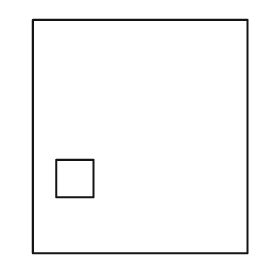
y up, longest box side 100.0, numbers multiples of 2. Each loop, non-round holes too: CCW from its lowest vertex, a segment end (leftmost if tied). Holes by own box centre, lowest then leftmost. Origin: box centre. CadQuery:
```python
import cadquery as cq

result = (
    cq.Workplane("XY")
    .moveTo(-46.0, -50.0)
    .lineTo(46.0, -50.0)
    .lineTo(46.0, 50.0)
    .lineTo(-46.0, 50.0)
    .close()
    .moveTo(-36.0, -26.0)
    .lineTo(-20.0, -26.0)
    .lineTo(-20.0, -10.0)
    .lineTo(-36.0, -10.0)
    .close()
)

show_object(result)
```